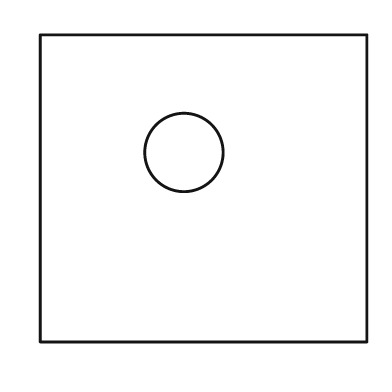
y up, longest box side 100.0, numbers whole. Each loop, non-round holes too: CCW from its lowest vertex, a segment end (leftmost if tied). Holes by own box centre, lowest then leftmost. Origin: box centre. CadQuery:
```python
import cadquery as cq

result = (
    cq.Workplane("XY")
    .moveTo(-50.0, -47.0)
    .lineTo(50.0, -47.0)
    .lineTo(50.0, 47.0)
    .lineTo(-50.0, 47.0)
    .close()
    .moveTo(-6.0, 11.0)
    .circle(12.0)
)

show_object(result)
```